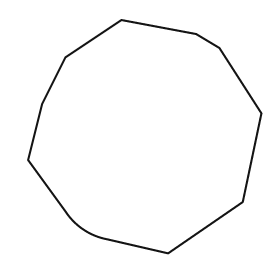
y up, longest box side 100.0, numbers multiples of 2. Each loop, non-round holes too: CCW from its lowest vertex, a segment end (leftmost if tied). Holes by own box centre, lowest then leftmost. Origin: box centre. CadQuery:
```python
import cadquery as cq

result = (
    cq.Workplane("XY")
    .moveTo(10.0, -50.0)
    .lineTo(42.0, -28.0)
    .lineTo(50.0, 10.0)
    .lineTo(32.0, 38.0)
    .lineTo(22.0, 44.0)
    .lineTo(-10.0, 50.0)
    .lineTo(-34.0, 34.0)
    .lineTo(-44.0, 14.0)
    .lineTo(-50.0, -10.0)
    .lineTo(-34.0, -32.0)
    .threePointArc((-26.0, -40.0), (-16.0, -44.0))
    .close()
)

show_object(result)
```